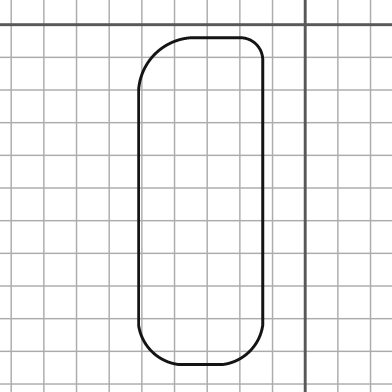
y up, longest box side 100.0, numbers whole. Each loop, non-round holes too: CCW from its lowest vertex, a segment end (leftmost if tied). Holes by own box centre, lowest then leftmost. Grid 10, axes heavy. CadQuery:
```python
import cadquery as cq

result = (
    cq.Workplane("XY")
    .moveTo(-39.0, -104.0)
    .lineTo(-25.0, -104.0)
    .threePointArc((-17.0, -100.0), (-13.0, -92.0))
    .lineTo(-13.0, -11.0)
    .threePointArc((-15.0, -6.0), (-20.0, -4.0))
    .lineTo(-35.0, -4.0)
    .threePointArc((-46.0, -9.0), (-51.0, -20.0))
    .lineTo(-51.0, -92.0)
    .threePointArc((-47.0, -100.0), (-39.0, -104.0))
    .close()
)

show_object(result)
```